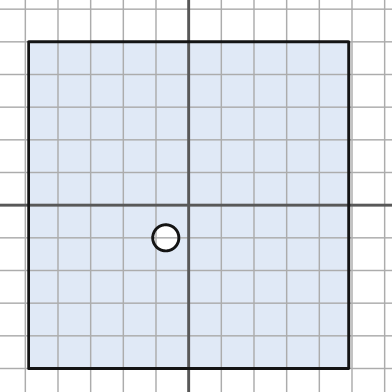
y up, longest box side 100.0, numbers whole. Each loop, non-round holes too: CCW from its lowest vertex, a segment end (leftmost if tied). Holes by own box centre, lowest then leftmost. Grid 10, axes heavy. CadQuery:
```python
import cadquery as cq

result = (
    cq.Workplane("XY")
    .moveTo(-49.0, -50.0)
    .lineTo(49.0, -50.0)
    .lineTo(49.0, 50.0)
    .lineTo(-49.0, 50.0)
    .close()
    .moveTo(-7.0, -10.0)
    .circle(4.0)
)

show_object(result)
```